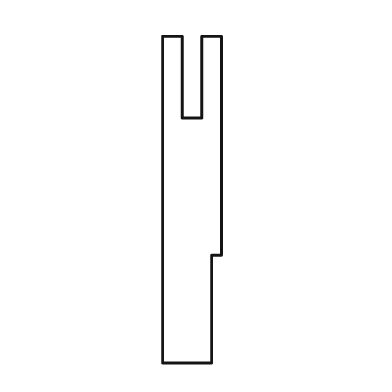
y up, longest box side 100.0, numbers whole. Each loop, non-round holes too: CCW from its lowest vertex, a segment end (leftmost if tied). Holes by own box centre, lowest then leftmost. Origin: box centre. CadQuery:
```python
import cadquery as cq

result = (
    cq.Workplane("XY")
    .moveTo(-9.0, -50.0)
    .lineTo(6.0, -50.0)
    .lineTo(6.0, -17.0)
    .lineTo(9.0, -17.0)
    .lineTo(9.0, 50.0)
    .lineTo(3.0, 50.0)
    .lineTo(3.0, 25.0)
    .lineTo(-3.0, 25.0)
    .lineTo(-3.0, 50.0)
    .lineTo(-9.0, 50.0)
    .close()
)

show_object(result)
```